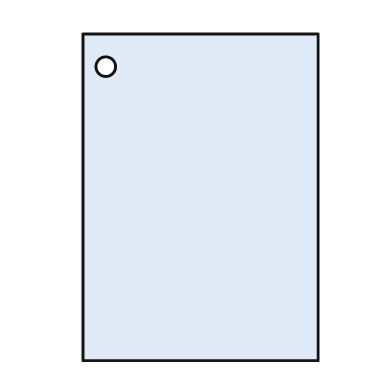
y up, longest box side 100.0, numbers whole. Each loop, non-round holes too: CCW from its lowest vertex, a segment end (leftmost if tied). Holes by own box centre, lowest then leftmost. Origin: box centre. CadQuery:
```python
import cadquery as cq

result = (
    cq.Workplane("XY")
    .moveTo(-36.0, -50.0)
    .lineTo(36.0, -50.0)
    .lineTo(36.0, 50.0)
    .lineTo(-36.0, 50.0)
    .close()
    .moveTo(-29.0, 40.0)
    .circle(3.0)
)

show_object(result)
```